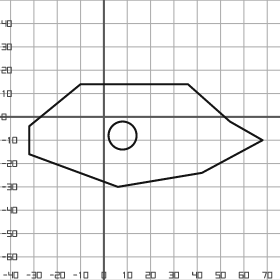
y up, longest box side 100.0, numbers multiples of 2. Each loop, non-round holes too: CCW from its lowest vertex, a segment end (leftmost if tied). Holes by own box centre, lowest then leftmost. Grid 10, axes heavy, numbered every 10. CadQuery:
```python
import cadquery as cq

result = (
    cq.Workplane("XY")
    .moveTo(6.0, -30.0)
    .lineTo(42.0, -24.0)
    .lineTo(68.0, -10.0)
    .lineTo(54.0, -2.0)
    .lineTo(36.0, 14.0)
    .lineTo(-10.0, 14.0)
    .lineTo(-32.0, -4.0)
    .lineTo(-32.0, -16.0)
    .close()
    .moveTo(8.0, -8.0)
    .circle(6.0)
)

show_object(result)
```